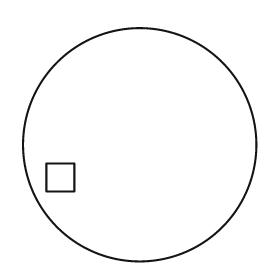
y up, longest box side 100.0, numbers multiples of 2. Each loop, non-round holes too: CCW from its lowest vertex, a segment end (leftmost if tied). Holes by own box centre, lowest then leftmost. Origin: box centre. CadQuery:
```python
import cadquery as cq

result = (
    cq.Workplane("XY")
    .moveTo(0.0, 0.0)
    .circle(50.0)
    .moveTo(-40.0, -20.0)
    .lineTo(-28.0, -20.0)
    .lineTo(-28.0, -8.0)
    .lineTo(-40.0, -8.0)
    .close()
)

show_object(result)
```